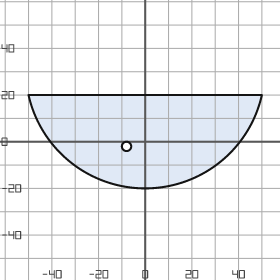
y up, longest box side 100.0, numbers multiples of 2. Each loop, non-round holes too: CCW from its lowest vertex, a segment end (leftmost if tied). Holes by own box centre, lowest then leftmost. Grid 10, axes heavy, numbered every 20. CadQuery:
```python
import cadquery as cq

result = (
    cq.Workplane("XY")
    .moveTo(-50.0, 20.0)
    .threePointArc((0.0, -20.0), (50.0, 20.0))
    .close()
    .moveTo(-8.0, -2.0)
    .circle(2.0)
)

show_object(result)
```